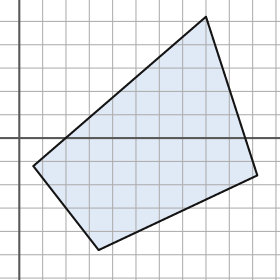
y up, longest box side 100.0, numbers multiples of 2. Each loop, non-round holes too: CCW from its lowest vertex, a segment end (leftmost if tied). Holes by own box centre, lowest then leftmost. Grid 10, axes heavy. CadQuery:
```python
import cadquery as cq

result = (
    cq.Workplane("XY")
    .moveTo(34.0, -48.0)
    .lineTo(102.0, -16.0)
    .lineTo(80.0, 52.0)
    .lineTo(6.0, -12.0)
    .close()
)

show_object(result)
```